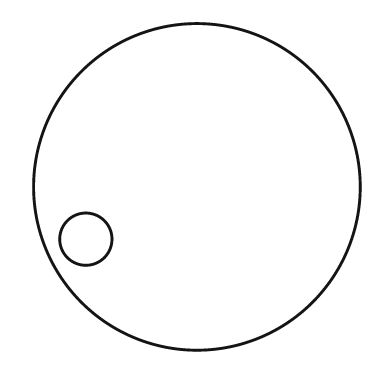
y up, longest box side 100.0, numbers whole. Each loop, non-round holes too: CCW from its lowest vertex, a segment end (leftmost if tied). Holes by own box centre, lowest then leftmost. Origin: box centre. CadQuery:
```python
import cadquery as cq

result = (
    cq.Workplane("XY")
    .moveTo(0.0, 0.0)
    .circle(50.0)
    .moveTo(-34.0, -16.0)
    .circle(8.0)
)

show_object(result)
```